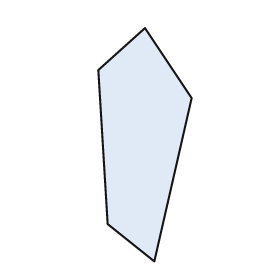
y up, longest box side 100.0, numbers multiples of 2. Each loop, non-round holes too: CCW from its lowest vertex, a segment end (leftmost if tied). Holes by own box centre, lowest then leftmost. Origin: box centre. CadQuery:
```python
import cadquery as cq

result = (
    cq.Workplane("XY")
    .moveTo(4.0, -50.0)
    .lineTo(20.0, 20.0)
    .lineTo(0.0, 50.0)
    .lineTo(-20.0, 32.0)
    .lineTo(-16.0, -34.0)
    .close()
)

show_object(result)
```